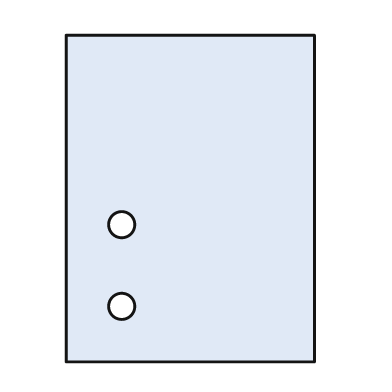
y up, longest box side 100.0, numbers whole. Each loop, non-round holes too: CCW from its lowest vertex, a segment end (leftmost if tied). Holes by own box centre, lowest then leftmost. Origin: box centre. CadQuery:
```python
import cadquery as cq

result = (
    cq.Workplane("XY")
    .moveTo(-38.0, -50.0)
    .lineTo(38.0, -50.0)
    .lineTo(38.0, 50.0)
    .lineTo(-38.0, 50.0)
    .close()
    .moveTo(-21.0, -33.0)
    .circle(4.0)
    .moveTo(-21.0, -8.0)
    .circle(4.0)
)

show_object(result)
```